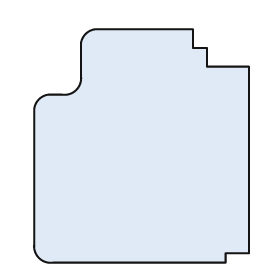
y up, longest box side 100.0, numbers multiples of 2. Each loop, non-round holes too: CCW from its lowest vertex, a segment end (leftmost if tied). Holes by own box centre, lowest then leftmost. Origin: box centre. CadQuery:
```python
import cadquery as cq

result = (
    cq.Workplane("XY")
    .moveTo(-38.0, -50.0)
    .lineTo(36.0, -50.0)
    .lineTo(36.0, -46.0)
    .lineTo(46.0, -46.0)
    .lineTo(46.0, 34.0)
    .lineTo(28.0, 34.0)
    .lineTo(28.0, 42.0)
    .lineTo(22.0, 42.0)
    .lineTo(22.0, 50.0)
    .lineTo(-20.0, 50.0)
    .threePointArc((-24.0, 48.0), (-26.0, 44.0))
    .lineTo(-26.0, 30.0)
    .threePointArc((-28.0, 24.0), (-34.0, 22.0))
    .lineTo(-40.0, 22.0)
    .threePointArc((-44.0, 20.0), (-46.0, 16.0))
    .lineTo(-46.0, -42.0)
    .threePointArc((-44.0, -48.0), (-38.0, -50.0))
    .close()
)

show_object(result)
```